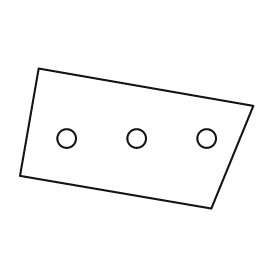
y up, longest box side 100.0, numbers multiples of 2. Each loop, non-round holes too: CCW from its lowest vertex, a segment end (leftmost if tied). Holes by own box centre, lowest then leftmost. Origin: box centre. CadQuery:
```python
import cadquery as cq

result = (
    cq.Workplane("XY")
    .moveTo(32.0, -30.0)
    .lineTo(50.0, 14.0)
    .lineTo(-42.0, 30.0)
    .lineTo(-50.0, -16.0)
    .close()
    .moveTo(-30.0, 0.0)
    .circle(4.0)
    .moveTo(0.0, 0.0)
    .circle(4.0)
    .moveTo(30.0, 0.0)
    .circle(4.0)
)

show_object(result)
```